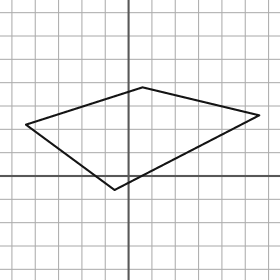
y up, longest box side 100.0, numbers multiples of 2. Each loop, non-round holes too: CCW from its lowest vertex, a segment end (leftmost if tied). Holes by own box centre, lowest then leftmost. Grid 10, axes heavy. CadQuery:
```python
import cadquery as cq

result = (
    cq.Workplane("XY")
    .moveTo(-6.0, -6.0)
    .lineTo(56.0, 26.0)
    .lineTo(6.0, 38.0)
    .lineTo(-44.0, 22.0)
    .close()
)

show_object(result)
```